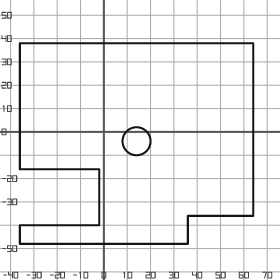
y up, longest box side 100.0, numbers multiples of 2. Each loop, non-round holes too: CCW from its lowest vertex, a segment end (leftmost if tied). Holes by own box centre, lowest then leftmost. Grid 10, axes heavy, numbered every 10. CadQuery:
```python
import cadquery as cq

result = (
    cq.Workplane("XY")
    .moveTo(-36.0, -48.0)
    .lineTo(36.0, -48.0)
    .lineTo(36.0, -36.0)
    .lineTo(64.0, -36.0)
    .lineTo(64.0, 38.0)
    .lineTo(-36.0, 38.0)
    .lineTo(-36.0, -16.0)
    .lineTo(-2.0, -16.0)
    .lineTo(-2.0, -40.0)
    .lineTo(-36.0, -40.0)
    .close()
    .moveTo(14.0, -4.0)
    .circle(6.0)
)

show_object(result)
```